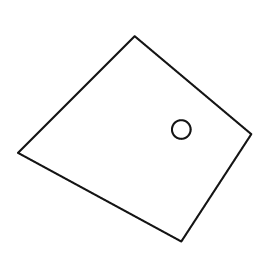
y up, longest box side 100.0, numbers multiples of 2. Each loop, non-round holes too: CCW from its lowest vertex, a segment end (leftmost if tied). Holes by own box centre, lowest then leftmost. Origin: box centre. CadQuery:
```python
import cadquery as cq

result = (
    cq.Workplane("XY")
    .moveTo(20.0, -44.0)
    .lineTo(50.0, 2.0)
    .lineTo(0.0, 44.0)
    .lineTo(-50.0, -6.0)
    .close()
    .moveTo(20.0, 4.0)
    .circle(4.0)
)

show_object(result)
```